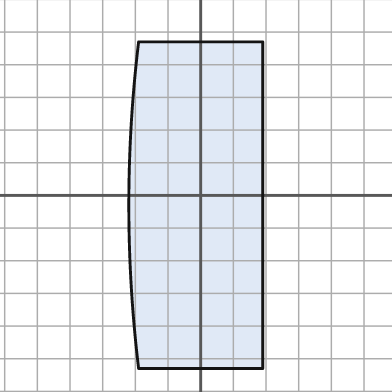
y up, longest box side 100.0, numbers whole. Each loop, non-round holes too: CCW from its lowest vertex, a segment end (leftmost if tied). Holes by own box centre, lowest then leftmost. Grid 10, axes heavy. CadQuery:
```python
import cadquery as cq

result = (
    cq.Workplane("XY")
    .moveTo(-19.0, -53.0)
    .lineTo(19.0, -53.0)
    .lineTo(19.0, 47.0)
    .lineTo(-19.0, 47.0)
    .threePointArc((-22.0, -3.0), (-19.0, -53.0))
    .close()
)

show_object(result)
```